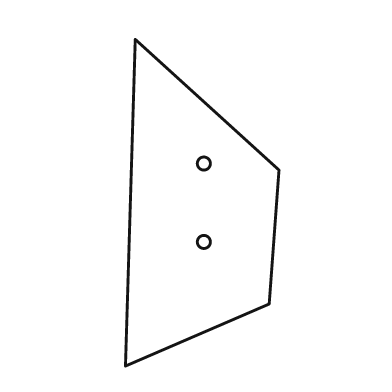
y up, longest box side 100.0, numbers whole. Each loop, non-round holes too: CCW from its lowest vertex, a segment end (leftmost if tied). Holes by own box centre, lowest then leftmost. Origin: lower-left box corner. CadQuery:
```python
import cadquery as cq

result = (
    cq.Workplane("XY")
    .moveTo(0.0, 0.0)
    .lineTo(44.0, 19.0)
    .lineTo(47.0, 60.0)
    .lineTo(3.0, 100.0)
    .close()
    .moveTo(24.0, 38.0)
    .circle(2.0)
    .moveTo(24.0, 62.0)
    .circle(2.0)
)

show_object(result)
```